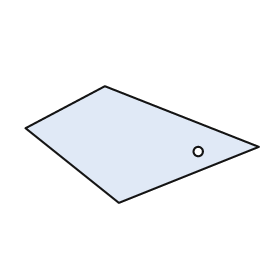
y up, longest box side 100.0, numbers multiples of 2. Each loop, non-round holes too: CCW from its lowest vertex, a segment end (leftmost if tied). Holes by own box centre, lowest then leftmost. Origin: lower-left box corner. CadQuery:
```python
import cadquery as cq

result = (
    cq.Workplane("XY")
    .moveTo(40.0, 0.0)
    .lineTo(100.0, 24.0)
    .lineTo(34.0, 50.0)
    .lineTo(0.0, 32.0)
    .close()
    .moveTo(74.0, 22.0)
    .circle(2.0)
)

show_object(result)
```